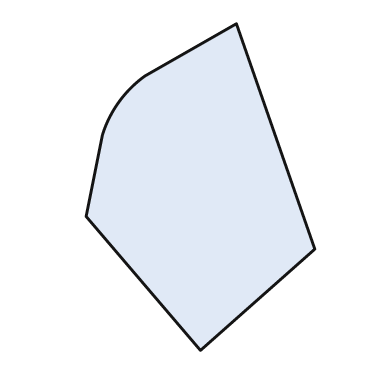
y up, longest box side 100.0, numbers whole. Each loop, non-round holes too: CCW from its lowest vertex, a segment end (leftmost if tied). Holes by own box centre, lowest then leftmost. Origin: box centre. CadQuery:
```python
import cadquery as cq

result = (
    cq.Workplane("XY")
    .moveTo(0.0, -50.0)
    .lineTo(35.0, -19.0)
    .lineTo(11.0, 50.0)
    .lineTo(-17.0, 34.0)
    .threePointArc((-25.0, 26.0), (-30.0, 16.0))
    .lineTo(-35.0, -9.0)
    .close()
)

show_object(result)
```